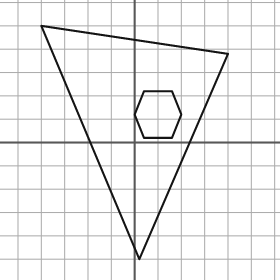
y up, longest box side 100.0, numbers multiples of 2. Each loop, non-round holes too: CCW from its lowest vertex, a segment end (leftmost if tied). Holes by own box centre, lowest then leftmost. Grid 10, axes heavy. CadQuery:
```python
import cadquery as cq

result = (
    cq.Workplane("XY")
    .moveTo(2.0, -50.0)
    .lineTo(40.0, 38.0)
    .lineTo(-40.0, 50.0)
    .close()
    .moveTo(4.0, 2.0)
    .lineTo(16.0, 2.0)
    .lineTo(20.0, 12.0)
    .lineTo(16.0, 22.0)
    .lineTo(4.0, 22.0)
    .lineTo(0.0, 12.0)
    .close()
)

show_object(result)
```